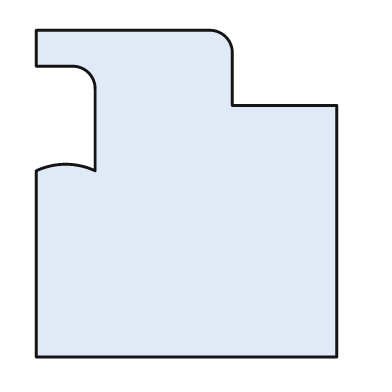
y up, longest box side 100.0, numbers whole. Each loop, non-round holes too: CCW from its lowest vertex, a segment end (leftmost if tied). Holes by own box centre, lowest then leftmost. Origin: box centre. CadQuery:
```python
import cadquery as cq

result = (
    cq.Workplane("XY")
    .moveTo(-46.0, -50.0)
    .lineTo(46.0, -50.0)
    .lineTo(46.0, 27.0)
    .lineTo(14.0, 27.0)
    .lineTo(14.0, 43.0)
    .threePointArc((12.0, 48.0), (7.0, 50.0))
    .lineTo(-46.0, 50.0)
    .lineTo(-46.0, 39.0)
    .lineTo(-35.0, 39.0)
    .threePointArc((-30.0, 37.0), (-28.0, 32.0))
    .lineTo(-28.0, 7.0)
    .threePointArc((-37.0, 9.0), (-46.0, 7.0))
    .close()
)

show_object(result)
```